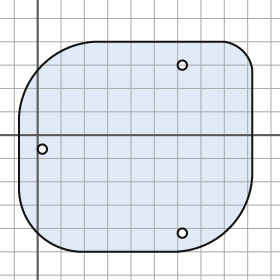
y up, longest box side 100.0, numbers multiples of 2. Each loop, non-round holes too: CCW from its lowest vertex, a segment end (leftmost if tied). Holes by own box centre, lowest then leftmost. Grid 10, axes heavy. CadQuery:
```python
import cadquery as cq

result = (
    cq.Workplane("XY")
    .moveTo(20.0, -50.0)
    .lineTo(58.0, -50.0)
    .threePointArc((82.0, -40.0), (92.0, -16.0))
    .lineTo(92.0, 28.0)
    .threePointArc((88.0, 36.0), (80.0, 40.0))
    .lineTo(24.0, 40.0)
    .threePointArc((2.0, 30.0), (-8.0, 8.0))
    .lineTo(-8.0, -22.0)
    .threePointArc((0.0, -42.0), (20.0, -50.0))
    .close()
    .moveTo(62.0, -42.0)
    .circle(2.0)
    .moveTo(2.0, -6.0)
    .circle(2.0)
    .moveTo(62.0, 30.0)
    .circle(2.0)
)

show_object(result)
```